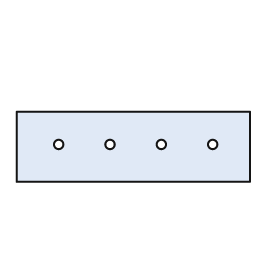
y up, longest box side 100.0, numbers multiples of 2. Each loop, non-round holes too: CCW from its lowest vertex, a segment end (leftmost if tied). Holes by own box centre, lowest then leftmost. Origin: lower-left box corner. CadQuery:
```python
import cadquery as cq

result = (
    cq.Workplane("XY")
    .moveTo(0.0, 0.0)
    .lineTo(100.0, 0.0)
    .lineTo(100.0, 30.0)
    .lineTo(0.0, 30.0)
    .close()
    .moveTo(18.0, 16.0)
    .circle(2.0)
    .moveTo(40.0, 16.0)
    .circle(2.0)
    .moveTo(62.0, 16.0)
    .circle(2.0)
    .moveTo(84.0, 16.0)
    .circle(2.0)
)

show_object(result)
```